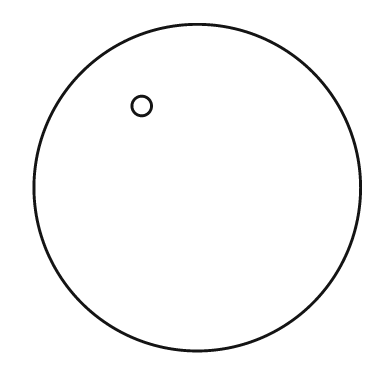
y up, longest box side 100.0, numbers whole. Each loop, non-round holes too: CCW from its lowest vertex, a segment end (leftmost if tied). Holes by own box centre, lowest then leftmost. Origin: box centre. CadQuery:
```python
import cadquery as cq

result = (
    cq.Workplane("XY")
    .moveTo(0.0, 0.0)
    .circle(50.0)
    .moveTo(-17.0, 25.0)
    .circle(3.0)
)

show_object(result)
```